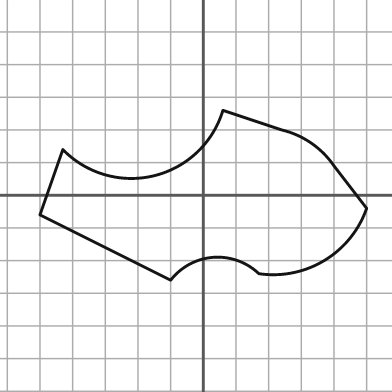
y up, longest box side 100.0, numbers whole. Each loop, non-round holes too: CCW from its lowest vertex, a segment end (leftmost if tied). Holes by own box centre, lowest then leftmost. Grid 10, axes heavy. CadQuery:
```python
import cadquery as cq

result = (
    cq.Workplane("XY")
    .moveTo(-10.0, -26.0)
    .threePointArc((3.0, -19.0), (17.0, -24.0))
    .threePointArc((37.0, -20.0), (50.0, -4.0))
    .lineTo(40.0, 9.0)
    .threePointArc((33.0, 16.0), (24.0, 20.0))
    .lineTo(6.0, 26.0)
    .threePointArc((-15.0, 6.0), (-43.0, 14.0))
    .lineTo(-50.0, -6.0)
    .close()
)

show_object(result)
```